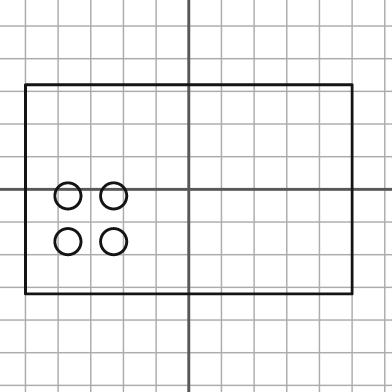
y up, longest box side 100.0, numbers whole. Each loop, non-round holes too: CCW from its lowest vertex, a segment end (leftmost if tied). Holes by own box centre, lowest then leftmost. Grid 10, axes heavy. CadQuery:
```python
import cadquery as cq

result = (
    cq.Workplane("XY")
    .moveTo(-50.0, -32.0)
    .lineTo(50.0, -32.0)
    .lineTo(50.0, 32.0)
    .lineTo(-50.0, 32.0)
    .close()
    .moveTo(-37.0, -16.0)
    .circle(4.0)
    .moveTo(-23.0, -16.0)
    .circle(4.0)
    .moveTo(-37.0, -2.0)
    .circle(4.0)
    .moveTo(-23.0, -2.0)
    .circle(4.0)
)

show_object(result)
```